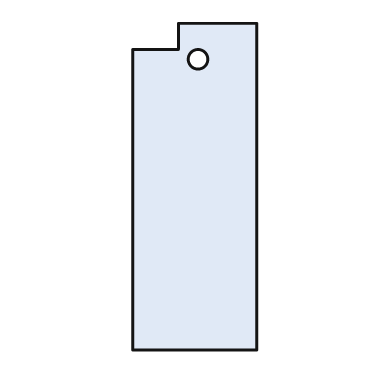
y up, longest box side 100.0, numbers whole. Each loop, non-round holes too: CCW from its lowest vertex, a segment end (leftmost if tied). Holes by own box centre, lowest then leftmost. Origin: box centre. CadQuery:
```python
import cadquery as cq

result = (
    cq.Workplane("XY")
    .moveTo(-19.0, -50.0)
    .lineTo(19.0, -50.0)
    .lineTo(19.0, 50.0)
    .lineTo(-5.0, 50.0)
    .lineTo(-5.0, 42.0)
    .lineTo(-19.0, 42.0)
    .close()
    .moveTo(1.0, 39.0)
    .circle(3.0)
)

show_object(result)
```